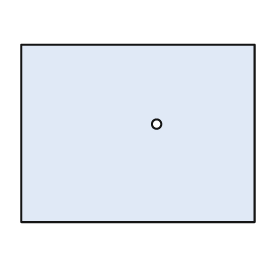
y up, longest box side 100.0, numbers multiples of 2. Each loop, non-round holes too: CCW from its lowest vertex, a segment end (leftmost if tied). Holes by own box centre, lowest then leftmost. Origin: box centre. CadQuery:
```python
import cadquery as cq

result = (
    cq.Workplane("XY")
    .moveTo(-50.0, -38.0)
    .lineTo(50.0, -38.0)
    .lineTo(50.0, 38.0)
    .lineTo(-50.0, 38.0)
    .close()
    .moveTo(8.0, 4.0)
    .circle(2.0)
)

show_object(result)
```